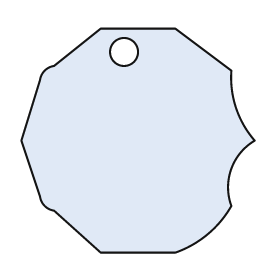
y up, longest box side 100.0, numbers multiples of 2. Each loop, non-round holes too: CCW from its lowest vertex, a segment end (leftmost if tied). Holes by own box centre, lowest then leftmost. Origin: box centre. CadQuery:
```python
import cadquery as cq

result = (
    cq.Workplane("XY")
    .moveTo(-16.0, -48.0)
    .lineTo(16.0, -48.0)
    .threePointArc((30.0, -40.0), (40.0, -28.0))
    .threePointArc((40.0, -12.0), (50.0, 0.0))
    .threePointArc((42.0, 14.0), (40.0, 30.0))
    .lineTo(16.0, 48.0)
    .lineTo(-16.0, 48.0)
    .lineTo(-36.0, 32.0)
    .threePointArc((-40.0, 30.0), (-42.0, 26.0))
    .lineTo(-50.0, 0.0)
    .lineTo(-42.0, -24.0)
    .threePointArc((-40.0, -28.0), (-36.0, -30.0))
    .close()
    .moveTo(-6.0, 38.0)
    .circle(6.0)
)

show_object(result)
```